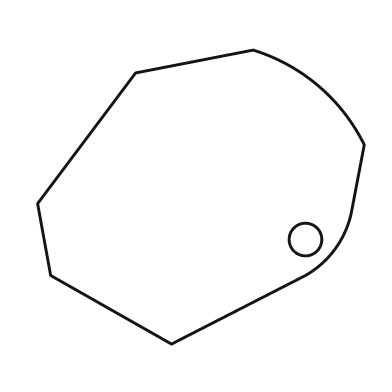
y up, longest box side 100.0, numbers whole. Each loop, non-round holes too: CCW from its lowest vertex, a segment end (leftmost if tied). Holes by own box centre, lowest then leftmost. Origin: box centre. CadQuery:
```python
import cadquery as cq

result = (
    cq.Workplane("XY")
    .moveTo(-9.0, -45.0)
    .lineTo(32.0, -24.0)
    .threePointArc((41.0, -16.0), (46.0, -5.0))
    .lineTo(50.0, 16.0)
    .threePointArc((36.0, 34.0), (16.0, 45.0))
    .lineTo(-20.0, 38.0)
    .lineTo(-50.0, -2.0)
    .lineTo(-46.0, -24.0)
    .close()
    .moveTo(32.0, -13.0)
    .circle(5.0)
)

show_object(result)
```